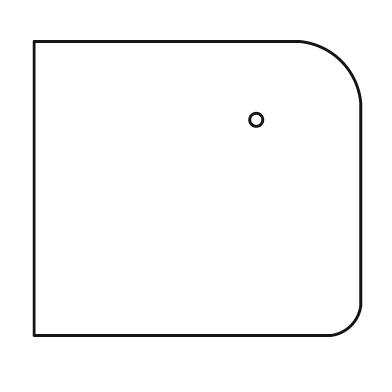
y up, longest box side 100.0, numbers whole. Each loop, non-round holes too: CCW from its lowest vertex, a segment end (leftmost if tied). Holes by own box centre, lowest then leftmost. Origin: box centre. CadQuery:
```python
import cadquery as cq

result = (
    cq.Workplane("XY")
    .moveTo(-50.0, -45.0)
    .lineTo(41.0, -45.0)
    .threePointArc((47.0, -42.0), (50.0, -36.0))
    .lineTo(50.0, 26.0)
    .threePointArc((44.0, 39.0), (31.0, 45.0))
    .lineTo(-50.0, 45.0)
    .close()
    .moveTo(18.0, 21.0)
    .circle(2.0)
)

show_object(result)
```